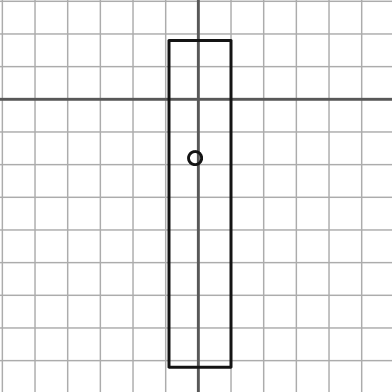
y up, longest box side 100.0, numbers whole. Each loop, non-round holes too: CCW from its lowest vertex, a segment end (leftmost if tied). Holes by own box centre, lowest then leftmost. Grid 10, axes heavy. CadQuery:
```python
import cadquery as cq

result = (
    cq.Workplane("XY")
    .moveTo(-9.0, -82.0)
    .lineTo(10.0, -82.0)
    .lineTo(10.0, 18.0)
    .lineTo(-9.0, 18.0)
    .close()
    .moveTo(-1.0, -18.0)
    .circle(2.0)
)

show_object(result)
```